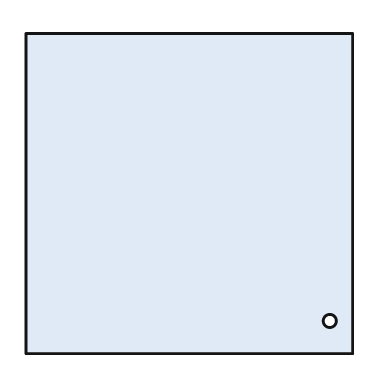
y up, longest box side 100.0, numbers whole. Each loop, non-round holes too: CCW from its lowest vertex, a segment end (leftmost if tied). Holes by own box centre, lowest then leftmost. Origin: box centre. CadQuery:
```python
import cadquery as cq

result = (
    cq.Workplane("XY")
    .moveTo(-50.0, -49.0)
    .lineTo(50.0, -49.0)
    .lineTo(50.0, 49.0)
    .lineTo(-50.0, 49.0)
    .close()
    .moveTo(43.0, -39.0)
    .circle(2.0)
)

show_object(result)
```